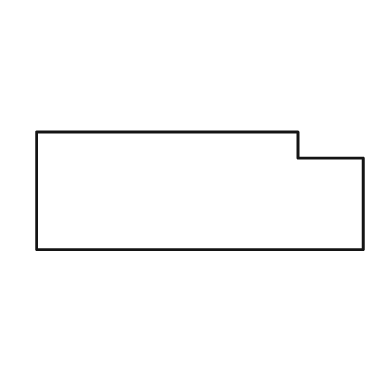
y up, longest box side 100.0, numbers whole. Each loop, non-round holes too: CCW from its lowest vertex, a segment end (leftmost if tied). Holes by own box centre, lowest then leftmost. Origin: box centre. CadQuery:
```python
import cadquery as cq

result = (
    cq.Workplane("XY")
    .moveTo(-50.0, -18.0)
    .lineTo(50.0, -18.0)
    .lineTo(50.0, 10.0)
    .lineTo(30.0, 10.0)
    .lineTo(30.0, 18.0)
    .lineTo(-50.0, 18.0)
    .close()
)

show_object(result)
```